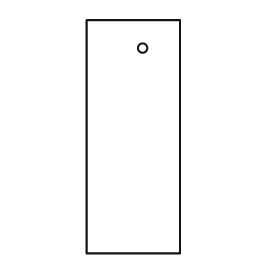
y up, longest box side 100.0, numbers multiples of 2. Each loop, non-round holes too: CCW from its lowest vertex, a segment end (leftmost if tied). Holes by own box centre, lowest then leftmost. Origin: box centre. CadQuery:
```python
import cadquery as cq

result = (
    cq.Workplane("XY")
    .moveTo(-20.0, -50.0)
    .lineTo(20.0, -50.0)
    .lineTo(20.0, 50.0)
    .lineTo(-20.0, 50.0)
    .close()
    .moveTo(4.0, 38.0)
    .circle(2.0)
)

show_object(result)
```